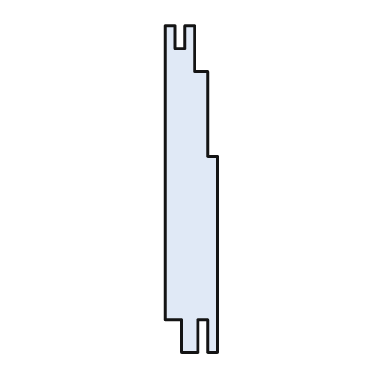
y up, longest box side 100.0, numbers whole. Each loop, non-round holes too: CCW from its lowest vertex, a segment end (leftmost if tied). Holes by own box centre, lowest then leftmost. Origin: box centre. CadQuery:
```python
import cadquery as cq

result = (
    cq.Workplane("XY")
    .moveTo(-3.0, -50.0)
    .lineTo(2.0, -50.0)
    .lineTo(2.0, -40.0)
    .lineTo(5.0, -40.0)
    .lineTo(5.0, -50.0)
    .lineTo(8.0, -50.0)
    .lineTo(8.0, 10.0)
    .lineTo(5.0, 10.0)
    .lineTo(5.0, 36.0)
    .lineTo(1.0, 36.0)
    .lineTo(1.0, 50.0)
    .lineTo(-2.0, 50.0)
    .lineTo(-2.0, 43.0)
    .lineTo(-5.0, 43.0)
    .lineTo(-5.0, 50.0)
    .lineTo(-8.0, 50.0)
    .lineTo(-8.0, -40.0)
    .lineTo(-3.0, -40.0)
    .close()
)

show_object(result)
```